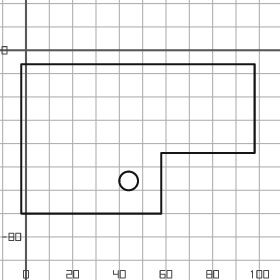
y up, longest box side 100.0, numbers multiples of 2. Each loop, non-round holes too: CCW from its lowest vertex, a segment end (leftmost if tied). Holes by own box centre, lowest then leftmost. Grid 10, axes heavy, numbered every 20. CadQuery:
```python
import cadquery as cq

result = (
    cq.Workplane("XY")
    .moveTo(-2.0, -70.0)
    .lineTo(58.0, -70.0)
    .lineTo(58.0, -44.0)
    .lineTo(98.0, -44.0)
    .lineTo(98.0, -6.0)
    .lineTo(-2.0, -6.0)
    .close()
    .moveTo(44.0, -56.0)
    .circle(4.0)
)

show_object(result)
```